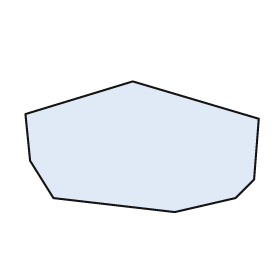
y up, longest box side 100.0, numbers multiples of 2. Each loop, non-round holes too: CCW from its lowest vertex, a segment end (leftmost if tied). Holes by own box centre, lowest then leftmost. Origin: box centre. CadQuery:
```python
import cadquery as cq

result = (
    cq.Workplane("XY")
    .moveTo(14.0, -28.0)
    .lineTo(40.0, -22.0)
    .lineTo(48.0, -14.0)
    .lineTo(50.0, 12.0)
    .lineTo(-4.0, 28.0)
    .lineTo(-50.0, 14.0)
    .lineTo(-48.0, -6.0)
    .lineTo(-38.0, -22.0)
    .close()
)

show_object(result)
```